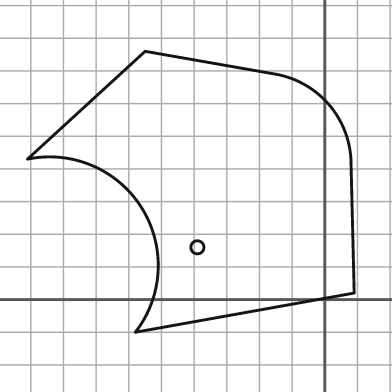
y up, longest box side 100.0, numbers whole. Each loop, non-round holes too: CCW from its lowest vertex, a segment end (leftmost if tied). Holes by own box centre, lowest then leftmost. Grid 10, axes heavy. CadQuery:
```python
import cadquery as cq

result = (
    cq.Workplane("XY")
    .moveTo(-58.0, -10.0)
    .lineTo(9.0, 2.0)
    .lineTo(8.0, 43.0)
    .threePointArc((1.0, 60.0), (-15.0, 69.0))
    .lineTo(-55.0, 76.0)
    .lineTo(-91.0, 43.0)
    .threePointArc((-56.0, 28.0), (-58.0, -10.0))
    .close()
    .moveTo(-39.0, 16.0)
    .circle(2.0)
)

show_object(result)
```